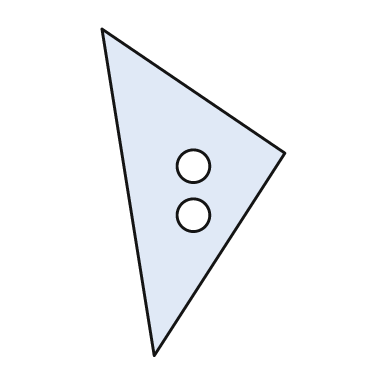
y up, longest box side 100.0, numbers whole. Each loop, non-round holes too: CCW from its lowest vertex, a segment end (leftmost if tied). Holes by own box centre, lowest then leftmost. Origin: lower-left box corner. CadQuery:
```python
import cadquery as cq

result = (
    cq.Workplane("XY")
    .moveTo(16.0, 0.0)
    .lineTo(56.0, 62.0)
    .lineTo(0.0, 100.0)
    .close()
    .moveTo(28.0, 43.0)
    .circle(5.0)
    .moveTo(28.0, 58.0)
    .circle(5.0)
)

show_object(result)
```